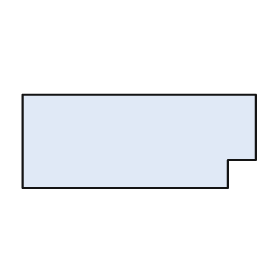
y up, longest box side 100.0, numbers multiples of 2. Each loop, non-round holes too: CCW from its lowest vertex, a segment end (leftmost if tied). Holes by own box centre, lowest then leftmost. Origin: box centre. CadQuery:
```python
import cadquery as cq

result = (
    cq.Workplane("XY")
    .moveTo(-50.0, -20.0)
    .lineTo(38.0, -20.0)
    .lineTo(38.0, -8.0)
    .lineTo(50.0, -8.0)
    .lineTo(50.0, 20.0)
    .lineTo(-50.0, 20.0)
    .close()
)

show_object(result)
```